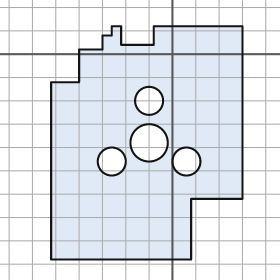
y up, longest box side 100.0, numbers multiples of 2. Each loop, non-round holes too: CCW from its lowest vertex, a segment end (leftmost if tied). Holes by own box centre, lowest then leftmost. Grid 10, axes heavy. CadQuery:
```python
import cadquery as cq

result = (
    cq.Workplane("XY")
    .moveTo(-52.0, -88.0)
    .lineTo(8.0, -88.0)
    .lineTo(8.0, -62.0)
    .lineTo(30.0, -62.0)
    .lineTo(30.0, 12.0)
    .lineTo(-8.0, 12.0)
    .lineTo(-8.0, 4.0)
    .lineTo(-22.0, 4.0)
    .lineTo(-22.0, 12.0)
    .lineTo(-26.0, 12.0)
    .lineTo(-26.0, 8.0)
    .lineTo(-30.0, 8.0)
    .lineTo(-30.0, 2.0)
    .lineTo(-40.0, 2.0)
    .lineTo(-40.0, -12.0)
    .lineTo(-52.0, -12.0)
    .close()
    .moveTo(-26.0, -46.0)
    .circle(6.0)
    .moveTo(6.0, -46.0)
    .circle(6.0)
    .moveTo(-10.0, -38.0)
    .circle(8.0)
    .moveTo(-10.0, -20.0)
    .circle(6.0)
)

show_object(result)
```